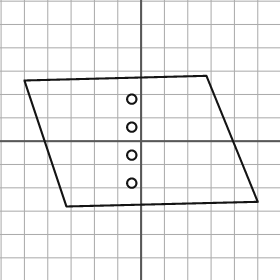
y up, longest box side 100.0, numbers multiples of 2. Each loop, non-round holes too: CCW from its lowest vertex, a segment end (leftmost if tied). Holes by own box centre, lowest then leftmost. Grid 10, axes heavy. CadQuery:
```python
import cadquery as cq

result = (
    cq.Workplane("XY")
    .moveTo(-32.0, -28.0)
    .lineTo(50.0, -26.0)
    .lineTo(28.0, 28.0)
    .lineTo(-50.0, 26.0)
    .close()
    .moveTo(-4.0, -18.0)
    .circle(2.0)
    .moveTo(-4.0, -6.0)
    .circle(2.0)
    .moveTo(-4.0, 6.0)
    .circle(2.0)
    .moveTo(-4.0, 18.0)
    .circle(2.0)
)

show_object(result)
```